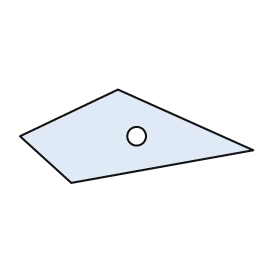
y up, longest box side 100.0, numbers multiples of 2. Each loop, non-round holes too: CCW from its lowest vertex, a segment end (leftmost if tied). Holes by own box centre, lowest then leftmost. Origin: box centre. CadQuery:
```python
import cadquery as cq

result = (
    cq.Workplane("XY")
    .moveTo(-28.0, -20.0)
    .lineTo(50.0, -6.0)
    .lineTo(-8.0, 20.0)
    .lineTo(-50.0, 0.0)
    .close()
    .moveTo(0.0, 0.0)
    .circle(4.0)
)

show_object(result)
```